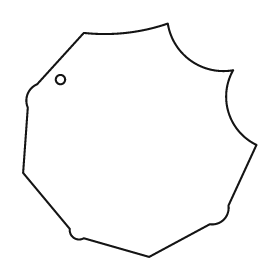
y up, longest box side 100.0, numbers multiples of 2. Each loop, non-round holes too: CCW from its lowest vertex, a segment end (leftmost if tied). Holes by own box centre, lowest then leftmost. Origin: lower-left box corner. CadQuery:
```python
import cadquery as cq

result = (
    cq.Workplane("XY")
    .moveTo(54.0, 0.0)
    .lineTo(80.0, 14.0)
    .threePointArc((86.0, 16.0), (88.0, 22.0))
    .lineTo(100.0, 48.0)
    .threePointArc((88.0, 62.0), (90.0, 80.0))
    .threePointArc((72.0, 84.0), (62.0, 100.0))
    .threePointArc((44.0, 96.0), (26.0, 96.0))
    .lineTo(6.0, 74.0)
    .threePointArc((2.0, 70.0), (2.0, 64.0))
    .lineTo(0.0, 36.0)
    .lineTo(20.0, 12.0)
    .threePointArc((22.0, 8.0), (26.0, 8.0))
    .close()
    .moveTo(16.0, 76.0)
    .circle(2.0)
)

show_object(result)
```